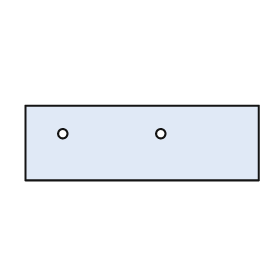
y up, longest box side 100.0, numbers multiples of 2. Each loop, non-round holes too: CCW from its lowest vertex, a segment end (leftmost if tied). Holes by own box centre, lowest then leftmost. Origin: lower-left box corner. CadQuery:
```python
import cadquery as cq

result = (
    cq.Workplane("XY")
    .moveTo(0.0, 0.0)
    .lineTo(100.0, 0.0)
    .lineTo(100.0, 32.0)
    .lineTo(0.0, 32.0)
    .close()
    .moveTo(16.0, 20.0)
    .circle(2.0)
    .moveTo(58.0, 20.0)
    .circle(2.0)
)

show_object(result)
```